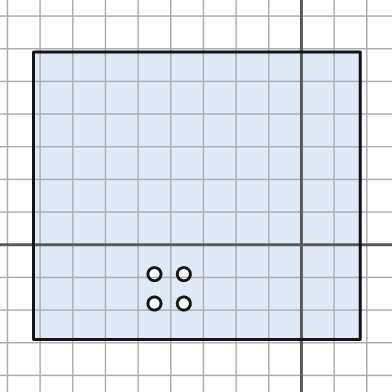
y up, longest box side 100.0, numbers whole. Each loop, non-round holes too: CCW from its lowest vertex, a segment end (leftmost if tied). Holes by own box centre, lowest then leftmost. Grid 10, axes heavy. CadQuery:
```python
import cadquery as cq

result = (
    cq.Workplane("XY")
    .moveTo(-82.0, -29.0)
    .lineTo(18.0, -29.0)
    .lineTo(18.0, 59.0)
    .lineTo(-82.0, 59.0)
    .close()
    .moveTo(-45.0, -18.0)
    .circle(2.0)
    .moveTo(-36.0, -18.0)
    .circle(2.0)
    .moveTo(-45.0, -9.0)
    .circle(2.0)
    .moveTo(-36.0, -9.0)
    .circle(2.0)
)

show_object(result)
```